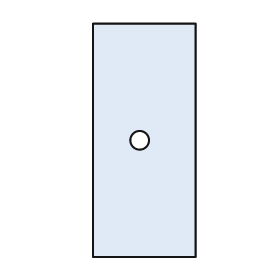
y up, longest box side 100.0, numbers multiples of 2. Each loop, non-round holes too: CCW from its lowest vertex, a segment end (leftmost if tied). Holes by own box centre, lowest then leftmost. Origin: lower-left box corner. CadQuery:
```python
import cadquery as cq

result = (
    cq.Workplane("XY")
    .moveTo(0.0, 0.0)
    .lineTo(44.0, 0.0)
    .lineTo(44.0, 100.0)
    .lineTo(0.0, 100.0)
    .close()
    .moveTo(20.0, 50.0)
    .circle(4.0)
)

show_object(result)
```